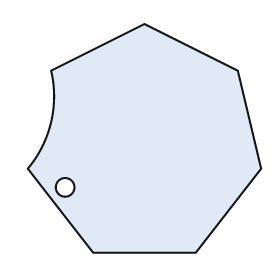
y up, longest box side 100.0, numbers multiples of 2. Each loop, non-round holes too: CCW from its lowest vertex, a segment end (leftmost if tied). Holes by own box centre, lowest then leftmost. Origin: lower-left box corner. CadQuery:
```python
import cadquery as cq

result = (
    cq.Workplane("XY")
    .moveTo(28.0, 0.0)
    .lineTo(72.0, 0.0)
    .lineTo(100.0, 36.0)
    .lineTo(90.0, 78.0)
    .lineTo(50.0, 98.0)
    .lineTo(10.0, 78.0)
    .threePointArc((10.0, 56.0), (0.0, 36.0))
    .close()
    .moveTo(16.0, 28.0)
    .circle(4.0)
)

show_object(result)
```